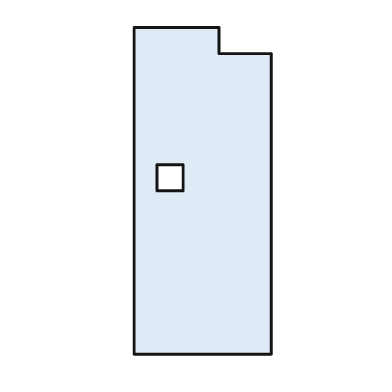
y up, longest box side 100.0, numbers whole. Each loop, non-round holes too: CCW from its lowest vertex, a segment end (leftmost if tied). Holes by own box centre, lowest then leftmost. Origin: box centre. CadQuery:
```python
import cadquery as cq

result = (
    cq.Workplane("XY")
    .moveTo(-21.0, -50.0)
    .lineTo(21.0, -50.0)
    .lineTo(21.0, 42.0)
    .lineTo(5.0, 42.0)
    .lineTo(5.0, 50.0)
    .lineTo(-21.0, 50.0)
    .close()
    .moveTo(-14.0, 0.0)
    .lineTo(-6.0, 0.0)
    .lineTo(-6.0, 8.0)
    .lineTo(-14.0, 8.0)
    .close()
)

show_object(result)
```